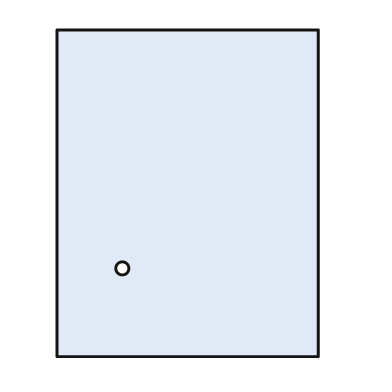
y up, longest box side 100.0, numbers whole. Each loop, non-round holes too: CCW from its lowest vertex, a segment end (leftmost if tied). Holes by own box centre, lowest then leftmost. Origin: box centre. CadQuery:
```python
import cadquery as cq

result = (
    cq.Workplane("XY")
    .moveTo(-40.0, -50.0)
    .lineTo(40.0, -50.0)
    .lineTo(40.0, 50.0)
    .lineTo(-40.0, 50.0)
    .close()
    .moveTo(-20.0, -23.0)
    .circle(2.0)
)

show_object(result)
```